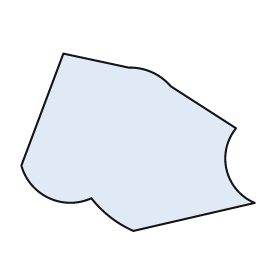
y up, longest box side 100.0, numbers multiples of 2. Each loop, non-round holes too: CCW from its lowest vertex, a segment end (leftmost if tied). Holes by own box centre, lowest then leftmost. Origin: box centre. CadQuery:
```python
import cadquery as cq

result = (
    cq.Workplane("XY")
    .moveTo(-2.0, -38.0)
    .lineTo(50.0, -26.0)
    .threePointArc((38.0, -12.0), (42.0, 6.0))
    .lineTo(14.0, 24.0)
    .threePointArc((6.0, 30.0), (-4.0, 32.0))
    .lineTo(-32.0, 38.0)
    .lineTo(-50.0, -10.0)
    .threePointArc((-38.0, -24.0), (-20.0, -24.0))
    .threePointArc((-12.0, -32.0), (-2.0, -38.0))
    .close()
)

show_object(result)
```